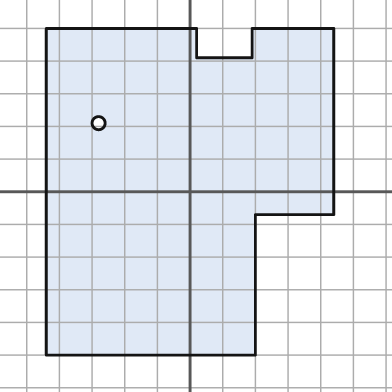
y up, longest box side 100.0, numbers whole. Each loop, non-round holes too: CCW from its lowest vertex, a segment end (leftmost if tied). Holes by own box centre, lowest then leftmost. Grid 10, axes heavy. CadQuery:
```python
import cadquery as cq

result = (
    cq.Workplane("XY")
    .moveTo(-44.0, -50.0)
    .lineTo(20.0, -50.0)
    .lineTo(20.0, -7.0)
    .lineTo(44.0, -7.0)
    .lineTo(44.0, 50.0)
    .lineTo(19.0, 50.0)
    .lineTo(19.0, 41.0)
    .lineTo(2.0, 41.0)
    .lineTo(2.0, 50.0)
    .lineTo(-44.0, 50.0)
    .close()
    .moveTo(-28.0, 21.0)
    .circle(2.0)
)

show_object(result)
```